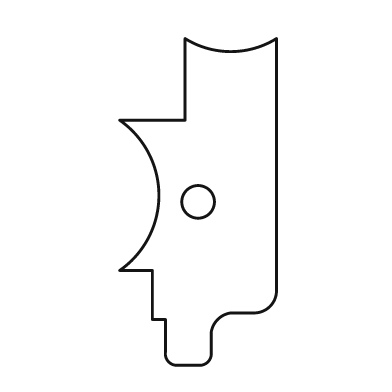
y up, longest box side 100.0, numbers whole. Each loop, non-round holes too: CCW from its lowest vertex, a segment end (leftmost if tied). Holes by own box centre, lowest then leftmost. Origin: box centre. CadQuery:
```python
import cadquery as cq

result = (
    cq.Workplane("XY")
    .moveTo(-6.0, -50.0)
    .lineTo(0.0, -50.0)
    .threePointArc((3.0, -49.0), (4.0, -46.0))
    .lineTo(4.0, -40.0)
    .threePointArc((6.0, -36.0), (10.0, -34.0))
    .lineTo(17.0, -34.0)
    .threePointArc((22.0, -32.0), (24.0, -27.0))
    .lineTo(24.0, 50.0)
    .threePointArc((10.0, 46.0), (-4.0, 50.0))
    .lineTo(-4.0, 25.0)
    .lineTo(-24.0, 25.0)
    .threePointArc((-12.0, 2.0), (-24.0, -21.0))
    .lineTo(-14.0, -21.0)
    .lineTo(-14.0, -36.0)
    .lineTo(-10.0, -36.0)
    .lineTo(-10.0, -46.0)
    .threePointArc((-9.0, -49.0), (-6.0, -50.0))
    .close()
    .moveTo(0.0, 0.0)
    .circle(5.0)
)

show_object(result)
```